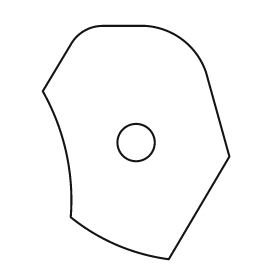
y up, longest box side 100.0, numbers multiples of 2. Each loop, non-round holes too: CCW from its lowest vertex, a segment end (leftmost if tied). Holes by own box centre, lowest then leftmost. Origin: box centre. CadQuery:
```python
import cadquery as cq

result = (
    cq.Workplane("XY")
    .moveTo(14.0, -50.0)
    .lineTo(40.0, -6.0)
    .lineTo(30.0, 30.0)
    .threePointArc((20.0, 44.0), (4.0, 50.0))
    .lineTo(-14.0, 50.0)
    .threePointArc((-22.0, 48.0), (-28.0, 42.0))
    .lineTo(-40.0, 22.0)
    .threePointArc((-30.0, -4.0), (-28.0, -32.0))
    .threePointArc((-8.0, -44.0), (14.0, -50.0))
    .close()
    .moveTo(0.0, 0.0)
    .circle(8.0)
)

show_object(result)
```